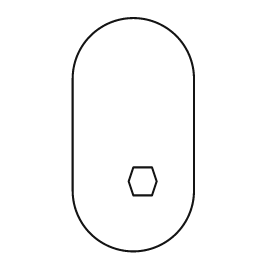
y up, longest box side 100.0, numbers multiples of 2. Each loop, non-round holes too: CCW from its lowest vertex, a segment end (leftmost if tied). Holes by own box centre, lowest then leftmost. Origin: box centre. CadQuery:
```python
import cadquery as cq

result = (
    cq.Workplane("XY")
    .moveTo(-26.0, -24.0)
    .threePointArc((0.0, -50.0), (26.0, -24.0))
    .lineTo(26.0, 24.0)
    .threePointArc((0.0, 50.0), (-26.0, 24.0))
    .close()
    .moveTo(0.0, -26.0)
    .lineTo(8.0, -26.0)
    .lineTo(10.0, -20.0)
    .lineTo(8.0, -14.0)
    .lineTo(0.0, -14.0)
    .lineTo(-2.0, -20.0)
    .close()
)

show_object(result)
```